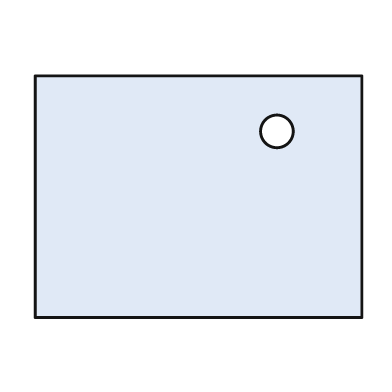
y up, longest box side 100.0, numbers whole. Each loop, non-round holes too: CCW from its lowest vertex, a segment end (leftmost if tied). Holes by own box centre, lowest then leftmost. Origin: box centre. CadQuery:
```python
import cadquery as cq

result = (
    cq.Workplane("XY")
    .moveTo(-50.0, -37.0)
    .lineTo(50.0, -37.0)
    .lineTo(50.0, 37.0)
    .lineTo(-50.0, 37.0)
    .close()
    .moveTo(24.0, 20.0)
    .circle(5.0)
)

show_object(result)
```